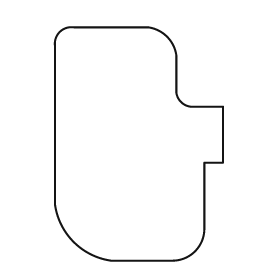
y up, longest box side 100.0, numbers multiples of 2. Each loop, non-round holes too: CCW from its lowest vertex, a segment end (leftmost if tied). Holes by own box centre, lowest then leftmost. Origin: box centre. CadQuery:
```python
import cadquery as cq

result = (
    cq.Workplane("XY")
    .moveTo(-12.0, -50.0)
    .lineTo(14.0, -50.0)
    .threePointArc((24.0, -46.0), (28.0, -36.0))
    .lineTo(28.0, -8.0)
    .lineTo(36.0, -8.0)
    .lineTo(36.0, 16.0)
    .lineTo(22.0, 16.0)
    .threePointArc((18.0, 18.0), (16.0, 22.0))
    .lineTo(16.0, 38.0)
    .threePointArc((12.0, 46.0), (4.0, 50.0))
    .lineTo(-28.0, 50.0)
    .threePointArc((-34.0, 48.0), (-36.0, 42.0))
    .lineTo(-36.0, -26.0)
    .threePointArc((-28.0, -42.0), (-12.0, -50.0))
    .close()
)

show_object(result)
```